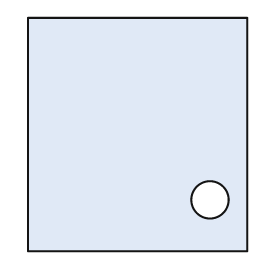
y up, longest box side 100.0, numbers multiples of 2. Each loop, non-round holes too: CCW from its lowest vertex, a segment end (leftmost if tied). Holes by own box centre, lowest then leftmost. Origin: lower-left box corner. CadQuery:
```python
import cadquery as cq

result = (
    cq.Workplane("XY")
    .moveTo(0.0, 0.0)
    .lineTo(94.0, 0.0)
    .lineTo(94.0, 100.0)
    .lineTo(0.0, 100.0)
    .close()
    .moveTo(78.0, 22.0)
    .circle(8.0)
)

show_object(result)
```